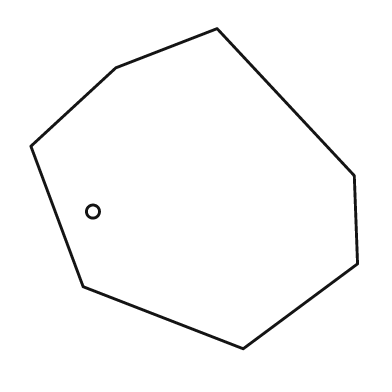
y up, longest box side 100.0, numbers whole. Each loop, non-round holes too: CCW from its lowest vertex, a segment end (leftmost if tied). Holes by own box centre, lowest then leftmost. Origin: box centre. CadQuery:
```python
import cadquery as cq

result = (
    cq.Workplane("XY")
    .moveTo(15.0, -49.0)
    .lineTo(50.0, -23.0)
    .lineTo(49.0, 4.0)
    .lineTo(7.0, 49.0)
    .lineTo(-24.0, 37.0)
    .lineTo(-50.0, 13.0)
    .lineTo(-34.0, -30.0)
    .close()
    .moveTo(-31.0, -7.0)
    .circle(2.0)
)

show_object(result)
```